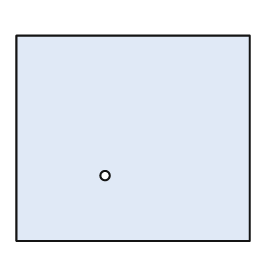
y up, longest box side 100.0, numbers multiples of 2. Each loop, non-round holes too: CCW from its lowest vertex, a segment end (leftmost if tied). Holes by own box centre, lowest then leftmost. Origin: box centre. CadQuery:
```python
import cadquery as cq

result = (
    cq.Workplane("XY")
    .moveTo(-50.0, -44.0)
    .lineTo(50.0, -44.0)
    .lineTo(50.0, 44.0)
    .lineTo(-50.0, 44.0)
    .close()
    .moveTo(-12.0, -16.0)
    .circle(2.0)
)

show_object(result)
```